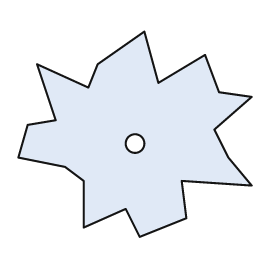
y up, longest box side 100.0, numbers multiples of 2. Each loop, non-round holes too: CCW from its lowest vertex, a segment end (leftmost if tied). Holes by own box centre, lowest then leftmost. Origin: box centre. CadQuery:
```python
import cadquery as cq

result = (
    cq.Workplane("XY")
    .moveTo(2.0, -44.0)
    .lineTo(22.0, -36.0)
    .lineTo(20.0, -20.0)
    .lineTo(50.0, -22.0)
    .lineTo(40.0, -10.0)
    .lineTo(34.0, 2.0)
    .lineTo(50.0, 16.0)
    .lineTo(36.0, 18.0)
    .lineTo(30.0, 34.0)
    .lineTo(10.0, 22.0)
    .lineTo(4.0, 44.0)
    .lineTo(-16.0, 30.0)
    .lineTo(-20.0, 20.0)
    .lineTo(-42.0, 30.0)
    .lineTo(-34.0, 6.0)
    .lineTo(-46.0, 4.0)
    .lineTo(-50.0, -10.0)
    .lineTo(-30.0, -14.0)
    .lineTo(-22.0, -20.0)
    .lineTo(-22.0, -40.0)
    .lineTo(-4.0, -32.0)
    .close()
    .moveTo(0.0, -4.0)
    .circle(4.0)
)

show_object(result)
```